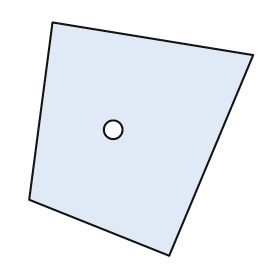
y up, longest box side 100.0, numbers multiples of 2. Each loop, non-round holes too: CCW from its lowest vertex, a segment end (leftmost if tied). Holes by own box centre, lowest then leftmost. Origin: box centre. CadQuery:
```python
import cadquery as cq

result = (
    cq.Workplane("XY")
    .moveTo(12.0, -50.0)
    .lineTo(48.0, 36.0)
    .lineTo(-38.0, 50.0)
    .lineTo(-48.0, -26.0)
    .close()
    .moveTo(-12.0, 4.0)
    .circle(4.0)
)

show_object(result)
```